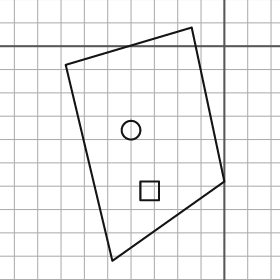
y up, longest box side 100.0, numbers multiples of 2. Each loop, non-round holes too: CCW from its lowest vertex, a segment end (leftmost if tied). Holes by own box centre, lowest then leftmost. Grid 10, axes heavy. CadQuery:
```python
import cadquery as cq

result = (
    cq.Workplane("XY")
    .moveTo(-48.0, -92.0)
    .lineTo(0.0, -58.0)
    .lineTo(-14.0, 8.0)
    .lineTo(-68.0, -8.0)
    .close()
    .moveTo(-36.0, -66.0)
    .lineTo(-28.0, -66.0)
    .lineTo(-28.0, -58.0)
    .lineTo(-36.0, -58.0)
    .close()
    .moveTo(-40.0, -36.0)
    .circle(4.0)
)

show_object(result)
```